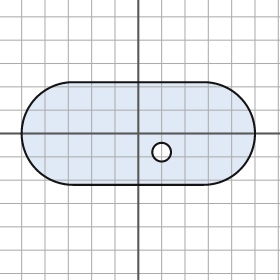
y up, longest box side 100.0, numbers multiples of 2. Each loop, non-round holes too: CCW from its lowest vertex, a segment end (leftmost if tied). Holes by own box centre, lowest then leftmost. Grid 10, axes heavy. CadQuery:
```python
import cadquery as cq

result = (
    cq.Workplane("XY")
    .moveTo(-28.0, -22.0)
    .lineTo(28.0, -22.0)
    .threePointArc((50.0, 0.0), (28.0, 22.0))
    .lineTo(-28.0, 22.0)
    .threePointArc((-50.0, 0.0), (-28.0, -22.0))
    .close()
    .moveTo(10.0, -8.0)
    .circle(4.0)
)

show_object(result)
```